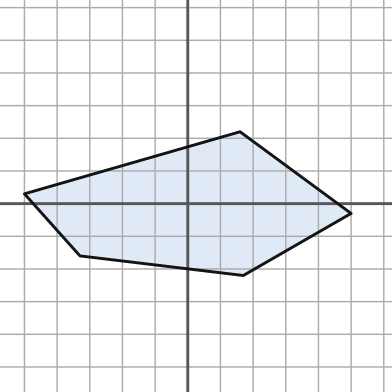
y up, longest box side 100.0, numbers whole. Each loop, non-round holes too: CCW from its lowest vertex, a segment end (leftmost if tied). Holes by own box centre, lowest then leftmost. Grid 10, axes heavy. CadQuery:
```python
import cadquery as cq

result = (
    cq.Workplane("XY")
    .moveTo(17.0, -22.0)
    .lineTo(50.0, -3.0)
    .lineTo(16.0, 22.0)
    .lineTo(-50.0, 3.0)
    .lineTo(-33.0, -16.0)
    .close()
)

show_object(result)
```